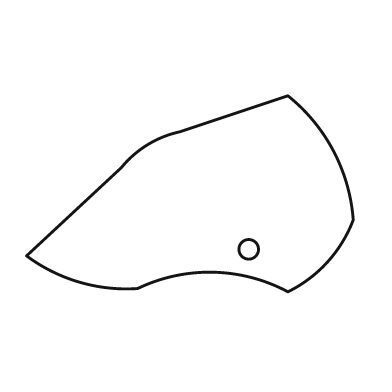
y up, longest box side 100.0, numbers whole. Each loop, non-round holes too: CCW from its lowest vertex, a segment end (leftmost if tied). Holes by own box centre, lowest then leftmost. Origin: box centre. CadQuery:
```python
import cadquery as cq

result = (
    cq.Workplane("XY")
    .moveTo(30.0, -30.0)
    .threePointArc((42.0, -21.0), (50.0, -8.0))
    .threePointArc((44.0, 13.0), (30.0, 30.0))
    .lineTo(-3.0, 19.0)
    .threePointArc((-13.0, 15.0), (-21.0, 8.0))
    .lineTo(-50.0, -19.0)
    .threePointArc((-34.0, -27.0), (-16.0, -29.0))
    .threePointArc((7.0, -24.0), (30.0, -30.0))
    .close()
    .moveTo(18.0, -17.0)
    .circle(3.0)
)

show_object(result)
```